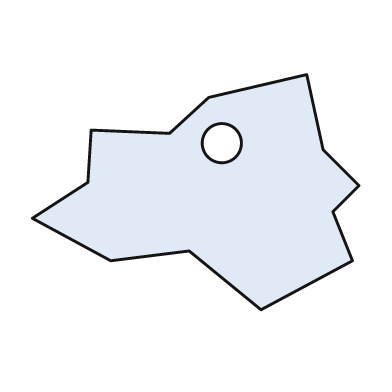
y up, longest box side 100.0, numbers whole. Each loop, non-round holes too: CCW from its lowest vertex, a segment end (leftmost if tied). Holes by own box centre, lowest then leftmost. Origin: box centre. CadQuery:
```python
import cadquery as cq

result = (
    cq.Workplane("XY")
    .moveTo(20.0, -36.0)
    .lineTo(48.0, -21.0)
    .lineTo(42.0, -6.0)
    .lineTo(50.0, 2.0)
    .lineTo(39.0, 13.0)
    .lineTo(34.0, 36.0)
    .lineTo(4.0, 29.0)
    .lineTo(-8.0, 18.0)
    .lineTo(-32.0, 19.0)
    .lineTo(-33.0, 3.0)
    .lineTo(-50.0, -8.0)
    .lineTo(-26.0, -21.0)
    .lineTo(-2.0, -18.0)
    .close()
    .moveTo(8.0, 15.0)
    .circle(6.0)
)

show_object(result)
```